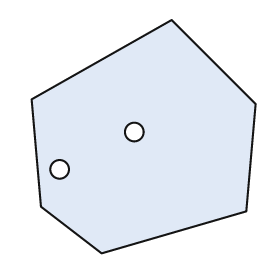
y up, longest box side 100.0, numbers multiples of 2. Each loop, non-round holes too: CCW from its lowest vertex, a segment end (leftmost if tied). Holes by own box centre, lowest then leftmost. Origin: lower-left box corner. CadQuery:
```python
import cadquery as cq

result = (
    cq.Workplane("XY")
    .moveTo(30.0, 0.0)
    .lineTo(92.0, 18.0)
    .lineTo(96.0, 64.0)
    .lineTo(60.0, 100.0)
    .lineTo(0.0, 66.0)
    .lineTo(4.0, 20.0)
    .close()
    .moveTo(12.0, 36.0)
    .circle(4.0)
    .moveTo(44.0, 52.0)
    .circle(4.0)
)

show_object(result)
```